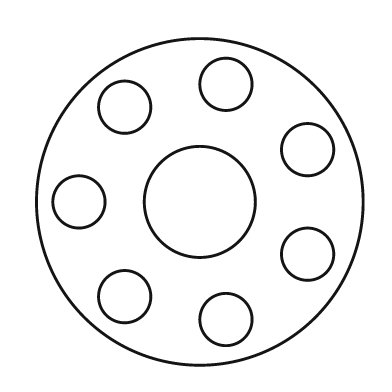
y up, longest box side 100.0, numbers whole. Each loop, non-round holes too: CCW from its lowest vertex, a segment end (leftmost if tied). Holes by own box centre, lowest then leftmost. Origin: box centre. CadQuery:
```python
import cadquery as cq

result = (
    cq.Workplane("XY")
    .moveTo(0.0, 0.0)
    .circle(50.0)
    .moveTo(8.0, -36.0)
    .circle(8.0)
    .moveTo(-23.0, -29.0)
    .circle(8.0)
    .moveTo(33.0, -16.0)
    .circle(8.0)
    .moveTo(-37.0, 0.0)
    .circle(8.0)
    .moveTo(0.0, 0.0)
    .circle(17.0)
    .moveTo(33.0, 16.0)
    .circle(8.0)
    .moveTo(-23.0, 29.0)
    .circle(8.0)
    .moveTo(8.0, 36.0)
    .circle(8.0)
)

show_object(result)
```